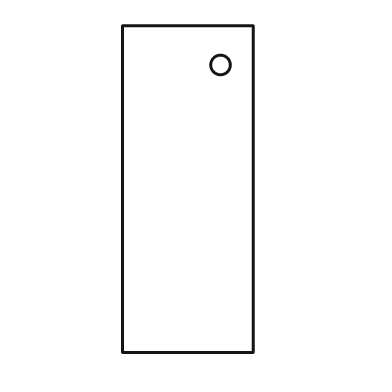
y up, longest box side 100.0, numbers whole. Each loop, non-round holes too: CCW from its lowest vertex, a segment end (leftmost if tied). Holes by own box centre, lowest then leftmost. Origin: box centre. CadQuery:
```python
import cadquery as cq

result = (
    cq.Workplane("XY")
    .moveTo(-20.0, -50.0)
    .lineTo(20.0, -50.0)
    .lineTo(20.0, 50.0)
    .lineTo(-20.0, 50.0)
    .close()
    .moveTo(10.0, 38.0)
    .circle(3.0)
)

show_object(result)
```